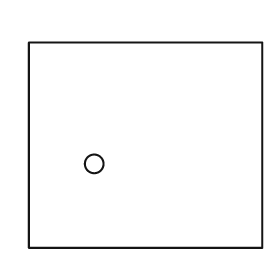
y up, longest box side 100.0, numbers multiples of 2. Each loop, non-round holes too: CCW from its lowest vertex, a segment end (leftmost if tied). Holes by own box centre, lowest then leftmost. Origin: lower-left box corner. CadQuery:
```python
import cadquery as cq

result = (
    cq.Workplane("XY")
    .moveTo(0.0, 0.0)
    .lineTo(100.0, 0.0)
    .lineTo(100.0, 88.0)
    .lineTo(0.0, 88.0)
    .close()
    .moveTo(28.0, 36.0)
    .circle(4.0)
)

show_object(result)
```